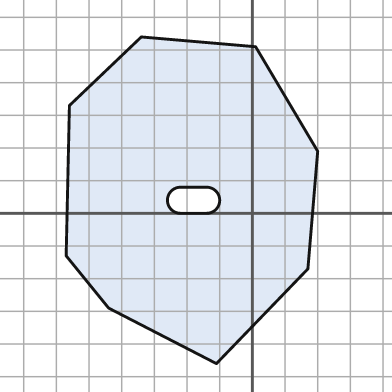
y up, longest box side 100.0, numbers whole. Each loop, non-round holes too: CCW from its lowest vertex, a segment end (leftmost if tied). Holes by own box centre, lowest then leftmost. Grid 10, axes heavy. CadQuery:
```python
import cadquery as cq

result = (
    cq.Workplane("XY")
    .moveTo(-11.0, -46.0)
    .lineTo(17.0, -17.0)
    .lineTo(20.0, 19.0)
    .lineTo(1.0, 51.0)
    .lineTo(-34.0, 54.0)
    .lineTo(-56.0, 33.0)
    .lineTo(-57.0, -13.0)
    .lineTo(-44.0, -29.0)
    .close()
    .moveTo(-22.0, 0.0)
    .lineTo(-14.0, 0.0)
    .threePointArc((-10.0, 4.0), (-14.0, 8.0))
    .lineTo(-22.0, 8.0)
    .threePointArc((-26.0, 4.0), (-22.0, 0.0))
    .close()
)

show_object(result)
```